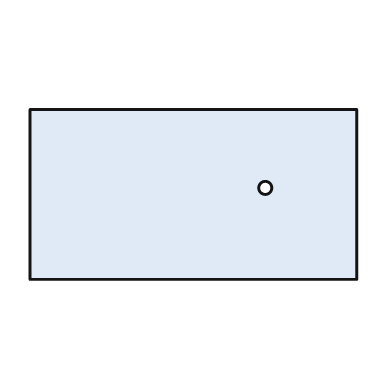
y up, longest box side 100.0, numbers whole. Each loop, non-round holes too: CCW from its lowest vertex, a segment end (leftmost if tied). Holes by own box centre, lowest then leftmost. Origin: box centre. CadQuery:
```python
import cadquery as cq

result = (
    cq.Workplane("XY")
    .moveTo(-50.0, -26.0)
    .lineTo(50.0, -26.0)
    .lineTo(50.0, 26.0)
    .lineTo(-50.0, 26.0)
    .close()
    .moveTo(22.0, 2.0)
    .circle(2.0)
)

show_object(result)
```